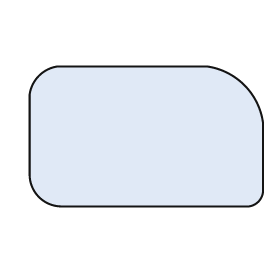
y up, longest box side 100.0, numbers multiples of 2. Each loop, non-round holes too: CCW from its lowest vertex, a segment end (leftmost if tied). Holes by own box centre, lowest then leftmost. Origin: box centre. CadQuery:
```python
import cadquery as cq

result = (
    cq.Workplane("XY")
    .moveTo(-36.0, -30.0)
    .lineTo(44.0, -30.0)
    .threePointArc((48.0, -28.0), (50.0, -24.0))
    .lineTo(50.0, 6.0)
    .threePointArc((42.0, 22.0), (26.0, 30.0))
    .lineTo(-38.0, 30.0)
    .threePointArc((-46.0, 26.0), (-50.0, 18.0))
    .lineTo(-50.0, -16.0)
    .threePointArc((-46.0, -26.0), (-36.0, -30.0))
    .close()
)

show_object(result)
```